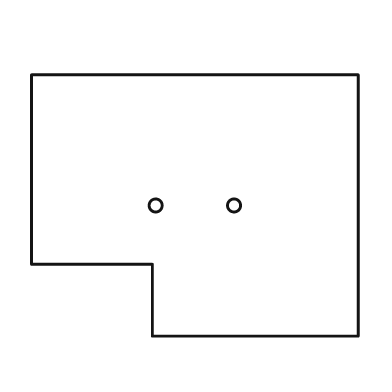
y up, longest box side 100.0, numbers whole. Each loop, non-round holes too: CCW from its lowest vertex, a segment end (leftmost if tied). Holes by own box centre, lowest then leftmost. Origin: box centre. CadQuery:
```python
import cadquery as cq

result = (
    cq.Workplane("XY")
    .moveTo(-13.0, -40.0)
    .lineTo(50.0, -40.0)
    .lineTo(50.0, 40.0)
    .lineTo(-50.0, 40.0)
    .lineTo(-50.0, -18.0)
    .lineTo(-13.0, -18.0)
    .close()
    .moveTo(-12.0, 0.0)
    .circle(2.0)
    .moveTo(12.0, 0.0)
    .circle(2.0)
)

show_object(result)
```